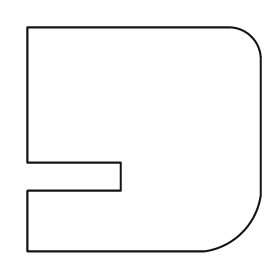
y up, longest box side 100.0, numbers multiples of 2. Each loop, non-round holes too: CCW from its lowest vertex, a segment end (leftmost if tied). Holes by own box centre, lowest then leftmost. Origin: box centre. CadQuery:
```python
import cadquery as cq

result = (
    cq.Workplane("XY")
    .moveTo(-50.0, -48.0)
    .lineTo(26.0, -48.0)
    .threePointArc((42.0, -40.0), (50.0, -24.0))
    .lineTo(50.0, 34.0)
    .threePointArc((46.0, 44.0), (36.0, 48.0))
    .lineTo(-50.0, 48.0)
    .lineTo(-50.0, -10.0)
    .lineTo(-10.0, -10.0)
    .lineTo(-10.0, -22.0)
    .lineTo(-50.0, -22.0)
    .close()
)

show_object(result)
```